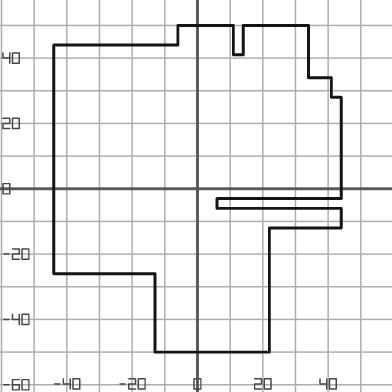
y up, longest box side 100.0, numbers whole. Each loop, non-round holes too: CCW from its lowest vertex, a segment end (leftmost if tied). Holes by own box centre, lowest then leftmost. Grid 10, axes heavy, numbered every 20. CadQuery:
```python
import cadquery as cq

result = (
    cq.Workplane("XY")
    .moveTo(-13.0, -50.0)
    .lineTo(22.0, -50.0)
    .lineTo(22.0, -12.0)
    .lineTo(44.0, -12.0)
    .lineTo(44.0, -6.0)
    .lineTo(6.0, -6.0)
    .lineTo(6.0, -3.0)
    .lineTo(44.0, -3.0)
    .lineTo(44.0, 28.0)
    .lineTo(41.0, 28.0)
    .lineTo(41.0, 34.0)
    .lineTo(34.0, 34.0)
    .lineTo(34.0, 50.0)
    .lineTo(14.0, 50.0)
    .lineTo(14.0, 41.0)
    .lineTo(11.0, 41.0)
    .lineTo(11.0, 50.0)
    .lineTo(-6.0, 50.0)
    .lineTo(-6.0, 44.0)
    .lineTo(-44.0, 44.0)
    .lineTo(-44.0, -26.0)
    .lineTo(-13.0, -26.0)
    .close()
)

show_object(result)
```